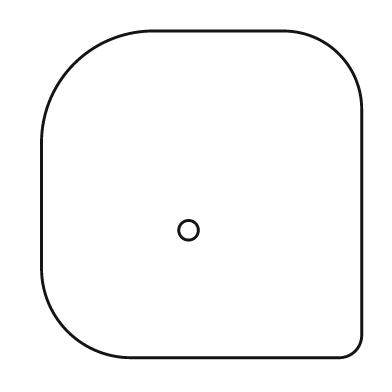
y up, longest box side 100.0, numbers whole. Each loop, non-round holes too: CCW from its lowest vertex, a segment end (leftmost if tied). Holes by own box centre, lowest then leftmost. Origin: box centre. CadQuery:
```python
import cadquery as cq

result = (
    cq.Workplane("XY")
    .moveTo(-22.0, -50.0)
    .lineTo(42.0, -50.0)
    .threePointArc((47.0, -48.0), (49.0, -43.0))
    .lineTo(49.0, 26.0)
    .threePointArc((42.0, 43.0), (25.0, 50.0))
    .lineTo(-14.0, 50.0)
    .threePointArc((-39.0, 40.0), (-49.0, 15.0))
    .lineTo(-49.0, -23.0)
    .threePointArc((-41.0, -42.0), (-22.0, -50.0))
    .close()
    .moveTo(-4.0, -11.0)
    .circle(3.0)
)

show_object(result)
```